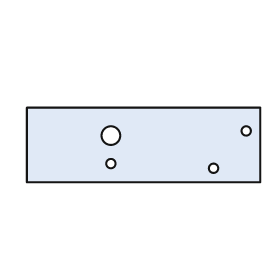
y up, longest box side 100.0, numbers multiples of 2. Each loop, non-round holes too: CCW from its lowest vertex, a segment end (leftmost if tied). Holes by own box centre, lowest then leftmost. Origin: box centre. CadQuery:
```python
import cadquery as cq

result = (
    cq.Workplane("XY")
    .moveTo(-50.0, -16.0)
    .lineTo(50.0, -16.0)
    .lineTo(50.0, 16.0)
    .lineTo(-50.0, 16.0)
    .close()
    .moveTo(30.0, -10.0)
    .circle(2.0)
    .moveTo(-14.0, -8.0)
    .circle(2.0)
    .moveTo(-14.0, 4.0)
    .circle(4.0)
    .moveTo(44.0, 6.0)
    .circle(2.0)
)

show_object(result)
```